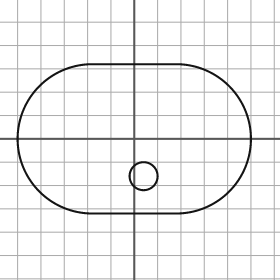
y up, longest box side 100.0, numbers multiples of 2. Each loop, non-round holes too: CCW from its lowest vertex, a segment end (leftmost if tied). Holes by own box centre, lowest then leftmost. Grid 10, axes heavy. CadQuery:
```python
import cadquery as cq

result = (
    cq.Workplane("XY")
    .moveTo(-18.0, -32.0)
    .lineTo(18.0, -32.0)
    .threePointArc((50.0, 0.0), (18.0, 32.0))
    .lineTo(-18.0, 32.0)
    .threePointArc((-50.0, 0.0), (-18.0, -32.0))
    .close()
    .moveTo(4.0, -16.0)
    .circle(6.0)
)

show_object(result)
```